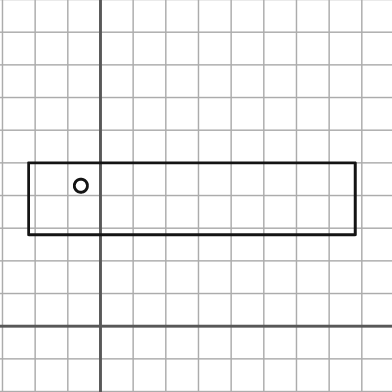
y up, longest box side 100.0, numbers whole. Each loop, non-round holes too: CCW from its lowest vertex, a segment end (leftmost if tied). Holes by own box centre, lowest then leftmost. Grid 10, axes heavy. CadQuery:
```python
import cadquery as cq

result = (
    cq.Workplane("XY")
    .moveTo(-22.0, 28.0)
    .lineTo(78.0, 28.0)
    .lineTo(78.0, 50.0)
    .lineTo(-22.0, 50.0)
    .close()
    .moveTo(-6.0, 43.0)
    .circle(2.0)
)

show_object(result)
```